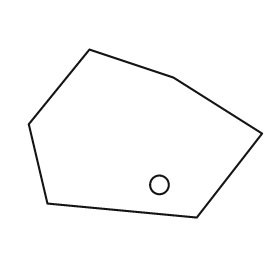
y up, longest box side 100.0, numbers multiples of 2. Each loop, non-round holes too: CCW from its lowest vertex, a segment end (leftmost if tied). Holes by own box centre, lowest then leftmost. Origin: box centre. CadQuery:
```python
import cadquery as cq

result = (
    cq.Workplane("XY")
    .moveTo(22.0, -36.0)
    .lineTo(50.0, 0.0)
    .lineTo(12.0, 24.0)
    .lineTo(-24.0, 36.0)
    .lineTo(-50.0, 4.0)
    .lineTo(-42.0, -30.0)
    .close()
    .moveTo(6.0, -22.0)
    .circle(4.0)
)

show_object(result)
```